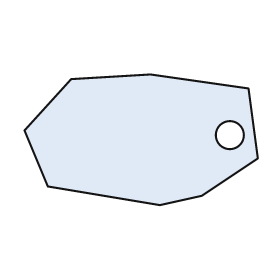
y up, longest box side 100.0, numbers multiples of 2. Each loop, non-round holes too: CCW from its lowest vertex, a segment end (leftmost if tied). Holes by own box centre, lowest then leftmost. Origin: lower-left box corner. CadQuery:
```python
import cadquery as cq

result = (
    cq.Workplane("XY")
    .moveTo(58.0, 0.0)
    .lineTo(76.0, 4.0)
    .lineTo(100.0, 20.0)
    .lineTo(96.0, 50.0)
    .lineTo(54.0, 56.0)
    .lineTo(20.0, 54.0)
    .lineTo(0.0, 32.0)
    .lineTo(10.0, 8.0)
    .close()
    .moveTo(88.0, 30.0)
    .circle(6.0)
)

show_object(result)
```